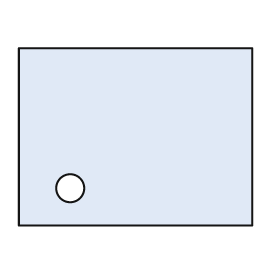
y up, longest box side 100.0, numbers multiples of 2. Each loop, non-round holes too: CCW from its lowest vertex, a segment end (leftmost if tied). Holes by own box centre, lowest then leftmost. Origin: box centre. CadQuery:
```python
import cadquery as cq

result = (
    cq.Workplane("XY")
    .moveTo(-50.0, -38.0)
    .lineTo(50.0, -38.0)
    .lineTo(50.0, 38.0)
    .lineTo(-50.0, 38.0)
    .close()
    .moveTo(-28.0, -22.0)
    .circle(6.0)
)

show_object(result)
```